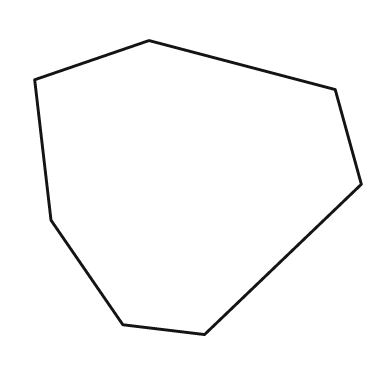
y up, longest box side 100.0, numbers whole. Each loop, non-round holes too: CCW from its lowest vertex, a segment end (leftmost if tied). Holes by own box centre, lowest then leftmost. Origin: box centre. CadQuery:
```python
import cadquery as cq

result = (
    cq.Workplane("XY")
    .moveTo(2.0, -45.0)
    .lineTo(50.0, 1.0)
    .lineTo(42.0, 30.0)
    .lineTo(-15.0, 45.0)
    .lineTo(-50.0, 33.0)
    .lineTo(-45.0, -10.0)
    .lineTo(-23.0, -42.0)
    .close()
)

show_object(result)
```